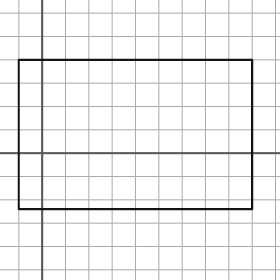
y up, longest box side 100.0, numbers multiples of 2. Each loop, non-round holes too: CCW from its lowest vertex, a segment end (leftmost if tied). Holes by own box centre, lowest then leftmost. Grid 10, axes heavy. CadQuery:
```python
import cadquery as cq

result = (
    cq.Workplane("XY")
    .moveTo(-10.0, -24.0)
    .lineTo(90.0, -24.0)
    .lineTo(90.0, 40.0)
    .lineTo(-10.0, 40.0)
    .close()
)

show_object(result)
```